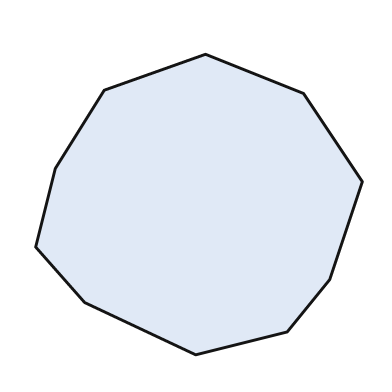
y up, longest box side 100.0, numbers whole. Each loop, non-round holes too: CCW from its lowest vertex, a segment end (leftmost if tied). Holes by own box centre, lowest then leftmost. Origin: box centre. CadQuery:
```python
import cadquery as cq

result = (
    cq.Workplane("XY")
    .moveTo(-1.0, -46.0)
    .lineTo(27.0, -39.0)
    .lineTo(40.0, -23.0)
    .lineTo(50.0, 7.0)
    .lineTo(32.0, 34.0)
    .lineTo(2.0, 46.0)
    .lineTo(-29.0, 35.0)
    .lineTo(-44.0, 11.0)
    .lineTo(-50.0, -13.0)
    .lineTo(-35.0, -30.0)
    .close()
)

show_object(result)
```